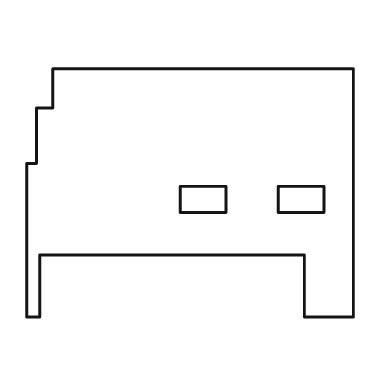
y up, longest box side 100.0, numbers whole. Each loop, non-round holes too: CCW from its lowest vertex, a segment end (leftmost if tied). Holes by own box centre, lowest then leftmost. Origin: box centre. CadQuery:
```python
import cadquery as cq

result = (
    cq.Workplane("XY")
    .moveTo(-50.0, -38.0)
    .lineTo(-46.0, -38.0)
    .lineTo(-46.0, -19.0)
    .lineTo(35.0, -19.0)
    .lineTo(35.0, -38.0)
    .lineTo(50.0, -38.0)
    .lineTo(50.0, 38.0)
    .lineTo(-42.0, 38.0)
    .lineTo(-42.0, 26.0)
    .lineTo(-47.0, 26.0)
    .lineTo(-47.0, 9.0)
    .lineTo(-50.0, 9.0)
    .close()
    .moveTo(-3.0, -6.0)
    .lineTo(11.0, -6.0)
    .lineTo(11.0, 2.0)
    .lineTo(-3.0, 2.0)
    .close()
    .moveTo(27.0, -6.0)
    .lineTo(41.0, -6.0)
    .lineTo(41.0, 2.0)
    .lineTo(27.0, 2.0)
    .close()
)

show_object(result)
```